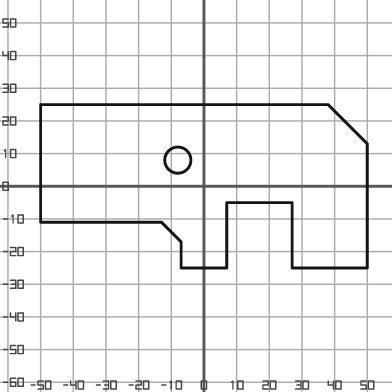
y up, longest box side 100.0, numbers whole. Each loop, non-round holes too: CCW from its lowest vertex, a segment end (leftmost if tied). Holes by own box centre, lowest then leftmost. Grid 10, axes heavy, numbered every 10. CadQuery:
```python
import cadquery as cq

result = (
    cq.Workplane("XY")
    .moveTo(-7.0, -25.0)
    .lineTo(7.0, -25.0)
    .lineTo(7.0, -5.0)
    .lineTo(27.0, -5.0)
    .lineTo(27.0, -25.0)
    .lineTo(50.0, -25.0)
    .lineTo(50.0, 13.0)
    .lineTo(38.0, 25.0)
    .lineTo(-50.0, 25.0)
    .lineTo(-50.0, -11.0)
    .lineTo(-13.0, -11.0)
    .lineTo(-7.0, -17.0)
    .close()
    .moveTo(-8.0, 8.0)
    .circle(4.0)
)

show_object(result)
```